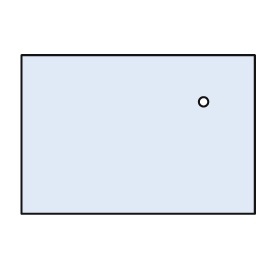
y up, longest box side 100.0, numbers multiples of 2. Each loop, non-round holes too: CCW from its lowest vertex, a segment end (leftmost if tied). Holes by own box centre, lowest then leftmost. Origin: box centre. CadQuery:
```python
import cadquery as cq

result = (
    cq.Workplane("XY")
    .moveTo(-50.0, -34.0)
    .lineTo(50.0, -34.0)
    .lineTo(50.0, 34.0)
    .lineTo(-50.0, 34.0)
    .close()
    .moveTo(28.0, 14.0)
    .circle(2.0)
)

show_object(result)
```